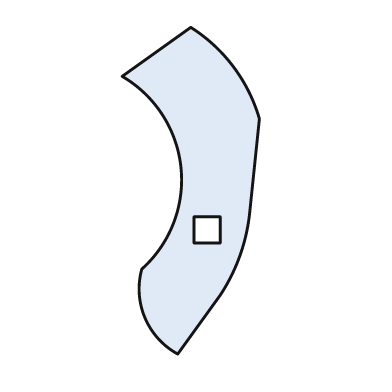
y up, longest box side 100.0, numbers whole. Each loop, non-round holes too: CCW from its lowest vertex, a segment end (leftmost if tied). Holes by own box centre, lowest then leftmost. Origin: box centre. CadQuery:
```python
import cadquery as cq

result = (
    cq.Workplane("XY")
    .moveTo(-4.0, -50.0)
    .lineTo(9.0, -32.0)
    .threePointArc((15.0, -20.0), (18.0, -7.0))
    .lineTo(21.0, 22.0)
    .threePointArc((13.0, 38.0), (0.0, 50.0))
    .lineTo(-21.0, 35.0)
    .threePointArc((-3.0, 7.0), (-15.0, -24.0))
    .threePointArc((-14.0, -39.0), (-4.0, -50.0))
    .close()
    .moveTo(1.0, -16.0)
    .lineTo(9.0, -16.0)
    .lineTo(9.0, -8.0)
    .lineTo(1.0, -8.0)
    .close()
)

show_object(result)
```